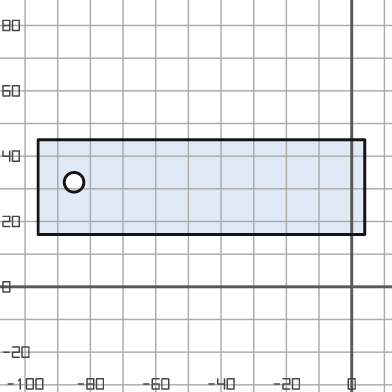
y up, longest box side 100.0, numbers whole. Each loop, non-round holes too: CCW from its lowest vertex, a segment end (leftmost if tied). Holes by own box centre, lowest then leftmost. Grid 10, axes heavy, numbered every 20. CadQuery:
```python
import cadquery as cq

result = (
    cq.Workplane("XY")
    .moveTo(-96.0, 16.0)
    .lineTo(4.0, 16.0)
    .lineTo(4.0, 45.0)
    .lineTo(-96.0, 45.0)
    .close()
    .moveTo(-85.0, 32.0)
    .circle(3.0)
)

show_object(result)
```